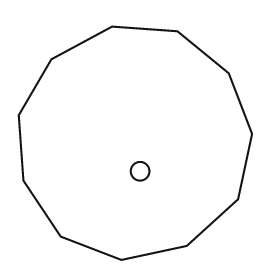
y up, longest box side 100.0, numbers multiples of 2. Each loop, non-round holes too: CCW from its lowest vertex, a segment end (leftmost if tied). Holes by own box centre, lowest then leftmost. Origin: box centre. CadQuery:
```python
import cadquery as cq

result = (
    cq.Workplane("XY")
    .moveTo(-6.0, -50.0)
    .lineTo(22.0, -44.0)
    .lineTo(44.0, -24.0)
    .lineTo(50.0, 4.0)
    .lineTo(40.0, 30.0)
    .lineTo(18.0, 48.0)
    .lineTo(-10.0, 50.0)
    .lineTo(-36.0, 36.0)
    .lineTo(-50.0, 12.0)
    .lineTo(-48.0, -16.0)
    .lineTo(-32.0, -40.0)
    .close()
    .moveTo(2.0, -12.0)
    .circle(4.0)
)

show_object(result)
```